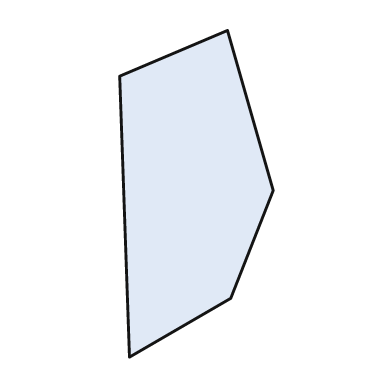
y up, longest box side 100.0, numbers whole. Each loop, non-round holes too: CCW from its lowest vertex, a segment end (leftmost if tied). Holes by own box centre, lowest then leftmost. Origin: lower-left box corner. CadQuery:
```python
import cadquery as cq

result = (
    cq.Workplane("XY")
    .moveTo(3.0, 0.0)
    .lineTo(34.0, 18.0)
    .lineTo(47.0, 51.0)
    .lineTo(33.0, 100.0)
    .lineTo(0.0, 86.0)
    .close()
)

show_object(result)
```